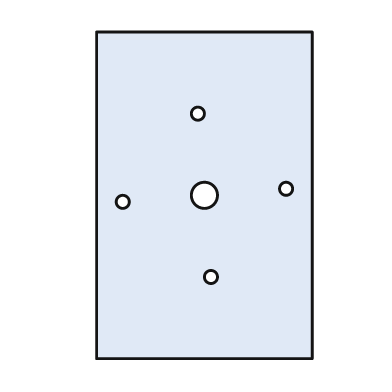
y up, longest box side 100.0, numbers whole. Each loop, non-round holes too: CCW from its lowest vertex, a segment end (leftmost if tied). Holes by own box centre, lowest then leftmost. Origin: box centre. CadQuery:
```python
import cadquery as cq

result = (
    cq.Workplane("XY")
    .moveTo(-33.0, -50.0)
    .lineTo(33.0, -50.0)
    .lineTo(33.0, 50.0)
    .lineTo(-33.0, 50.0)
    .close()
    .moveTo(2.0, -25.0)
    .circle(2.0)
    .moveTo(-25.0, -2.0)
    .circle(2.0)
    .moveTo(0.0, 0.0)
    .circle(4.0)
    .moveTo(25.0, 2.0)
    .circle(2.0)
    .moveTo(-2.0, 25.0)
    .circle(2.0)
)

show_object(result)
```